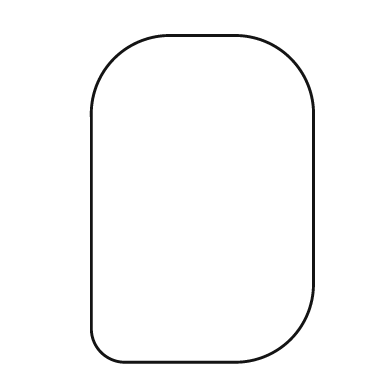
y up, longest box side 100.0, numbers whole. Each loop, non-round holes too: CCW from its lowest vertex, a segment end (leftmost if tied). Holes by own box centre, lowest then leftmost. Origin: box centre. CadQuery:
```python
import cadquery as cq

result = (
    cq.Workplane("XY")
    .moveTo(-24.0, -50.0)
    .lineTo(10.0, -50.0)
    .threePointArc((27.0, -43.0), (34.0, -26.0))
    .lineTo(34.0, 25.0)
    .threePointArc((27.0, 43.0), (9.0, 50.0))
    .lineTo(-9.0, 50.0)
    .threePointArc((-27.0, 43.0), (-34.0, 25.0))
    .lineTo(-34.0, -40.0)
    .threePointArc((-31.0, -47.0), (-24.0, -50.0))
    .close()
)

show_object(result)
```